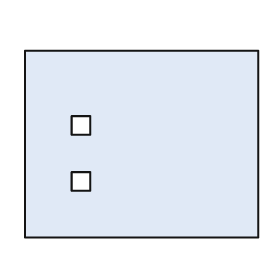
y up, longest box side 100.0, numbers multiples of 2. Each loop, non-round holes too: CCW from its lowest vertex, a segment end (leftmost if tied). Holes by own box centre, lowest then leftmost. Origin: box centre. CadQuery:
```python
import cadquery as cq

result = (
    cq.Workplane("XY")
    .moveTo(-50.0, -40.0)
    .lineTo(50.0, -40.0)
    .lineTo(50.0, 40.0)
    .lineTo(-50.0, 40.0)
    .close()
    .moveTo(-30.0, -20.0)
    .lineTo(-22.0, -20.0)
    .lineTo(-22.0, -12.0)
    .lineTo(-30.0, -12.0)
    .close()
    .moveTo(-30.0, 4.0)
    .lineTo(-22.0, 4.0)
    .lineTo(-22.0, 12.0)
    .lineTo(-30.0, 12.0)
    .close()
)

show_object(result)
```